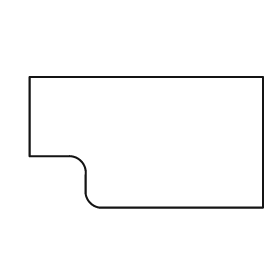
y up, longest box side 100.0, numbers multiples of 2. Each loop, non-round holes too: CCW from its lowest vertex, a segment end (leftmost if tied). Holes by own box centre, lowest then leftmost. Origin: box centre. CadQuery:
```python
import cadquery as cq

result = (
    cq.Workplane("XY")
    .moveTo(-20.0, -28.0)
    .lineTo(50.0, -28.0)
    .lineTo(50.0, 28.0)
    .lineTo(-50.0, 28.0)
    .lineTo(-50.0, -6.0)
    .lineTo(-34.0, -6.0)
    .threePointArc((-28.0, -8.0), (-26.0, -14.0))
    .lineTo(-26.0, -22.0)
    .threePointArc((-24.0, -26.0), (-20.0, -28.0))
    .close()
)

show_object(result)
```